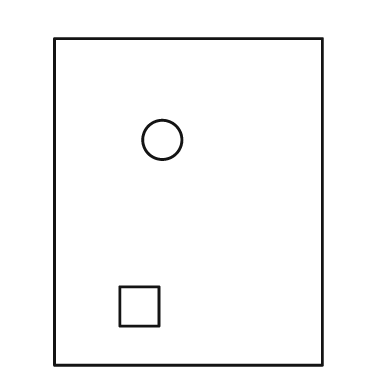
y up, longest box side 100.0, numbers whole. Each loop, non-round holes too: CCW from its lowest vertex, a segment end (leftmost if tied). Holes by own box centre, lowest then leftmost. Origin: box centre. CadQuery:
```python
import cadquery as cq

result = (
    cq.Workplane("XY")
    .moveTo(-41.0, -50.0)
    .lineTo(41.0, -50.0)
    .lineTo(41.0, 50.0)
    .lineTo(-41.0, 50.0)
    .close()
    .moveTo(-21.0, -38.0)
    .lineTo(-9.0, -38.0)
    .lineTo(-9.0, -26.0)
    .lineTo(-21.0, -26.0)
    .close()
    .moveTo(-8.0, 19.0)
    .circle(6.0)
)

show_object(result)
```